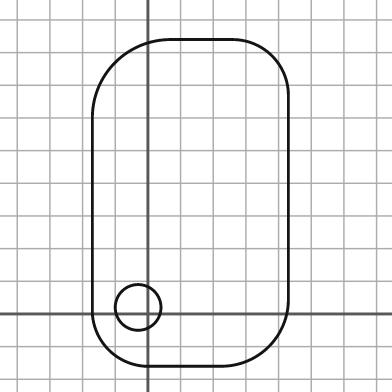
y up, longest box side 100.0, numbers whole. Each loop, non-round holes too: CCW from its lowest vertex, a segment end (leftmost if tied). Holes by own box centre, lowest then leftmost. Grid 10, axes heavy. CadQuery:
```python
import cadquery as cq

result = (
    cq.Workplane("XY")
    .moveTo(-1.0, -16.0)
    .lineTo(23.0, -16.0)
    .threePointArc((37.0, -10.0), (43.0, 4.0))
    .lineTo(43.0, 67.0)
    .threePointArc((38.0, 79.0), (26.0, 84.0))
    .lineTo(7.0, 84.0)
    .threePointArc((-10.0, 77.0), (-17.0, 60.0))
    .lineTo(-17.0, 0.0)
    .threePointArc((-12.0, -11.0), (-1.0, -16.0))
    .close()
    .moveTo(-3.0, 2.0)
    .circle(7.0)
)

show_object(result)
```